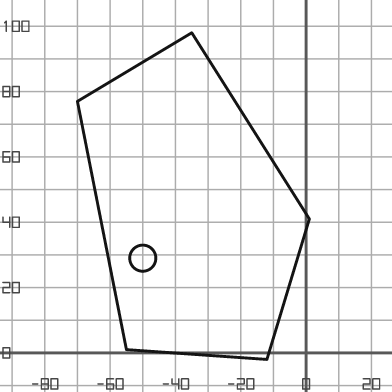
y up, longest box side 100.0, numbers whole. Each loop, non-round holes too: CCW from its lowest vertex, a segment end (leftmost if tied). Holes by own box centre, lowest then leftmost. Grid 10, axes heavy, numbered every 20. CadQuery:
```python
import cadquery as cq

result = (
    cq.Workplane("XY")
    .moveTo(-12.0, -2.0)
    .lineTo(1.0, 41.0)
    .lineTo(-35.0, 98.0)
    .lineTo(-70.0, 77.0)
    .lineTo(-55.0, 1.0)
    .close()
    .moveTo(-50.0, 29.0)
    .circle(4.0)
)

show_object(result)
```